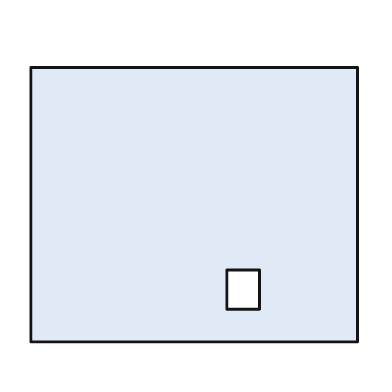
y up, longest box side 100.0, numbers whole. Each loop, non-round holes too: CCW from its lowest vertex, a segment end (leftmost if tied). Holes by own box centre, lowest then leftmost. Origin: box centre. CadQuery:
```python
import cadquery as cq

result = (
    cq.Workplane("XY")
    .moveTo(-50.0, -42.0)
    .lineTo(50.0, -42.0)
    .lineTo(50.0, 42.0)
    .lineTo(-50.0, 42.0)
    .close()
    .moveTo(10.0, -32.0)
    .lineTo(20.0, -32.0)
    .lineTo(20.0, -20.0)
    .lineTo(10.0, -20.0)
    .close()
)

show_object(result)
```